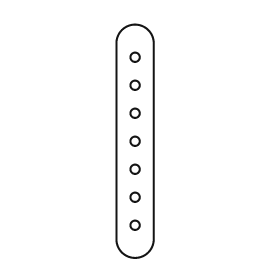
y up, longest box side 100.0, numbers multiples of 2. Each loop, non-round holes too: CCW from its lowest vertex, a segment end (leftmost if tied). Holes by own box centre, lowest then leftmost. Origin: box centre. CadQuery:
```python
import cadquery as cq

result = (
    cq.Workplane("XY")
    .moveTo(-8.0, -42.0)
    .threePointArc((0.0, -50.0), (8.0, -42.0))
    .lineTo(8.0, 42.0)
    .threePointArc((0.0, 50.0), (-8.0, 42.0))
    .close()
    .moveTo(0.0, -36.0)
    .circle(2.0)
    .moveTo(0.0, -24.0)
    .circle(2.0)
    .moveTo(0.0, -12.0)
    .circle(2.0)
    .moveTo(0.0, 0.0)
    .circle(2.0)
    .moveTo(0.0, 12.0)
    .circle(2.0)
    .moveTo(0.0, 24.0)
    .circle(2.0)
    .moveTo(0.0, 36.0)
    .circle(2.0)
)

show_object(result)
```